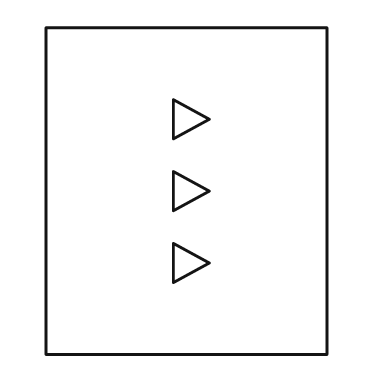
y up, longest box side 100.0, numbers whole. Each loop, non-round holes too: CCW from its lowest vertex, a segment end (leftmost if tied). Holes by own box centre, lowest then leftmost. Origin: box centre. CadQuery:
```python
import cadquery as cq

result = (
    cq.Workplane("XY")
    .moveTo(-43.0, -50.0)
    .lineTo(43.0, -50.0)
    .lineTo(43.0, 50.0)
    .lineTo(-43.0, 50.0)
    .close()
    .moveTo(-4.0, -28.0)
    .lineTo(7.0, -22.0)
    .lineTo(-4.0, -16.0)
    .close()
    .moveTo(-4.0, -6.0)
    .lineTo(7.0, 0.0)
    .lineTo(-4.0, 6.0)
    .close()
    .moveTo(-4.0, 16.0)
    .lineTo(7.0, 22.0)
    .lineTo(-4.0, 28.0)
    .close()
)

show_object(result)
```